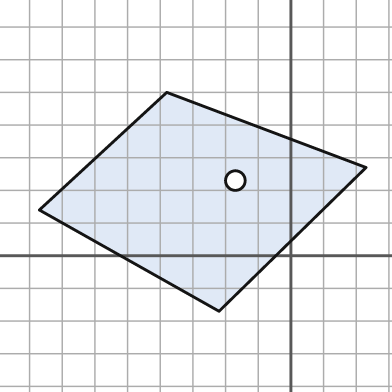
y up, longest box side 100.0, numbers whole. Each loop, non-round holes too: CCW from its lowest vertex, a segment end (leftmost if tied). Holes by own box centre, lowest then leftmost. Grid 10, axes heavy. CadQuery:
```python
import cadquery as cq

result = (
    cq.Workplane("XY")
    .moveTo(-22.0, -17.0)
    .lineTo(23.0, 27.0)
    .lineTo(-38.0, 50.0)
    .lineTo(-77.0, 14.0)
    .close()
    .moveTo(-17.0, 23.0)
    .circle(3.0)
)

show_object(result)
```